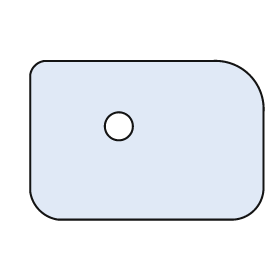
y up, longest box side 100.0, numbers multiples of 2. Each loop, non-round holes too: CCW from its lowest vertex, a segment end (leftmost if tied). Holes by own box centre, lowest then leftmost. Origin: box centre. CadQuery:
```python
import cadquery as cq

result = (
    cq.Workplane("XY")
    .moveTo(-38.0, -34.0)
    .lineTo(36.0, -34.0)
    .threePointArc((46.0, -30.0), (50.0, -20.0))
    .lineTo(50.0, 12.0)
    .threePointArc((44.0, 28.0), (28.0, 34.0))
    .lineTo(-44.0, 34.0)
    .threePointArc((-48.0, 32.0), (-50.0, 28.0))
    .lineTo(-50.0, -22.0)
    .threePointArc((-46.0, -30.0), (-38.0, -34.0))
    .close()
    .moveTo(-12.0, 6.0)
    .circle(6.0)
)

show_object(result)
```